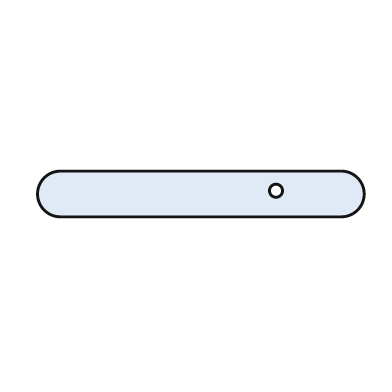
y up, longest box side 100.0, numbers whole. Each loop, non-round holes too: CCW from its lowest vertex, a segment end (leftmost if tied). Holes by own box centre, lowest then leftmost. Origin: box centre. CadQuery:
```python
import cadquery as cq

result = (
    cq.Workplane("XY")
    .moveTo(-43.0, -7.0)
    .lineTo(43.0, -7.0)
    .threePointArc((50.0, 0.0), (43.0, 7.0))
    .lineTo(-43.0, 7.0)
    .threePointArc((-50.0, 0.0), (-43.0, -7.0))
    .close()
    .moveTo(23.0, 1.0)
    .circle(2.0)
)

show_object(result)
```